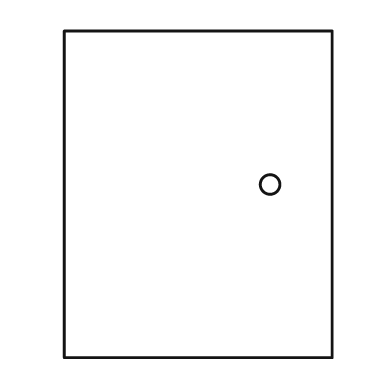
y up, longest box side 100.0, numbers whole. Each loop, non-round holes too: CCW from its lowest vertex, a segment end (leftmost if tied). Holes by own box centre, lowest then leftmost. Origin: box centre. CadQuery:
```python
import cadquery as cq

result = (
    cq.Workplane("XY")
    .moveTo(-41.0, -50.0)
    .lineTo(41.0, -50.0)
    .lineTo(41.0, 50.0)
    .lineTo(-41.0, 50.0)
    .close()
    .moveTo(22.0, 3.0)
    .circle(3.0)
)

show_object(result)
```